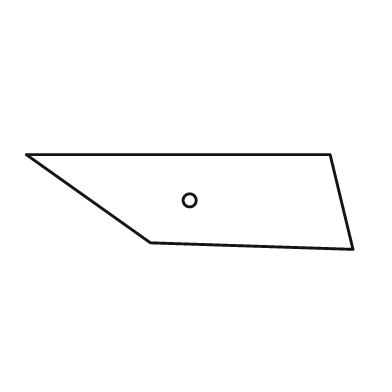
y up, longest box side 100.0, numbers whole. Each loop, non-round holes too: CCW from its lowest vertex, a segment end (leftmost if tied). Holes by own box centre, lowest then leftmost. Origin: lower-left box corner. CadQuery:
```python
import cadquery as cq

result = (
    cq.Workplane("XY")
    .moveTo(100.0, 0.0)
    .lineTo(93.0, 29.0)
    .lineTo(0.0, 29.0)
    .lineTo(38.0, 2.0)
    .close()
    .moveTo(50.0, 15.0)
    .circle(2.0)
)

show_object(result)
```